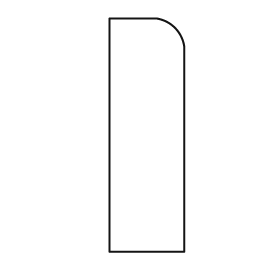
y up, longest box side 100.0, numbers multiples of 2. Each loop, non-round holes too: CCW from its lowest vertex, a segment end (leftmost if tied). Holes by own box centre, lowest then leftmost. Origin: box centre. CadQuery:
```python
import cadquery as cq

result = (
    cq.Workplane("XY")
    .moveTo(-16.0, -50.0)
    .lineTo(16.0, -50.0)
    .lineTo(16.0, 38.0)
    .threePointArc((12.0, 46.0), (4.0, 50.0))
    .lineTo(-16.0, 50.0)
    .close()
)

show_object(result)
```